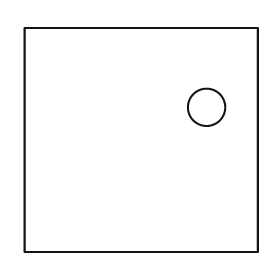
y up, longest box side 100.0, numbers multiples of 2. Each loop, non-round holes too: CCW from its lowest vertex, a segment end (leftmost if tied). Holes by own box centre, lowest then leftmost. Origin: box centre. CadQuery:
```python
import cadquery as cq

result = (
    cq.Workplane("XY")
    .moveTo(-50.0, -48.0)
    .lineTo(50.0, -48.0)
    .lineTo(50.0, 48.0)
    .lineTo(-50.0, 48.0)
    .close()
    .moveTo(28.0, 14.0)
    .circle(8.0)
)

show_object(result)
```